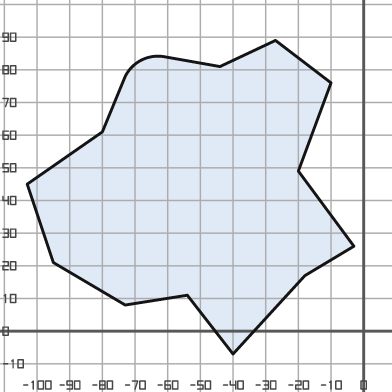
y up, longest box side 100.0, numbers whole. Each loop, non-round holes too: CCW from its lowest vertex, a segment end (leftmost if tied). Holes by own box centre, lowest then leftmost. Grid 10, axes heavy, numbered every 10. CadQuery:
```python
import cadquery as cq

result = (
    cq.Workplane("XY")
    .moveTo(-40.0, -7.0)
    .lineTo(-18.0, 17.0)
    .lineTo(-3.0, 26.0)
    .lineTo(-20.0, 49.0)
    .lineTo(-10.0, 76.0)
    .lineTo(-27.0, 89.0)
    .lineTo(-44.0, 81.0)
    .lineTo(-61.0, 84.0)
    .threePointArc((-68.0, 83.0), (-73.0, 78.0))
    .lineTo(-80.0, 61.0)
    .lineTo(-103.0, 45.0)
    .lineTo(-95.0, 21.0)
    .lineTo(-73.0, 8.0)
    .lineTo(-54.0, 11.0)
    .close()
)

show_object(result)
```